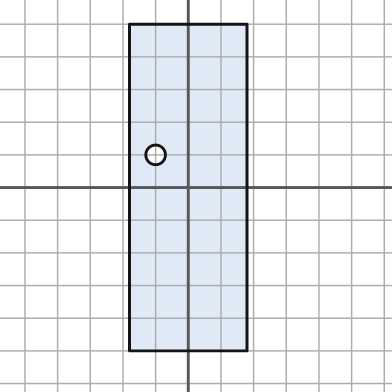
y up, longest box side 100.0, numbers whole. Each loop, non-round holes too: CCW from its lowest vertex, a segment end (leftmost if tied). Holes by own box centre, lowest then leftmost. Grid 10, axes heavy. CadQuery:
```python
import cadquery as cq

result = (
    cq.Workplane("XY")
    .moveTo(-18.0, -50.0)
    .lineTo(18.0, -50.0)
    .lineTo(18.0, 50.0)
    .lineTo(-18.0, 50.0)
    .close()
    .moveTo(-10.0, 10.0)
    .circle(3.0)
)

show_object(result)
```